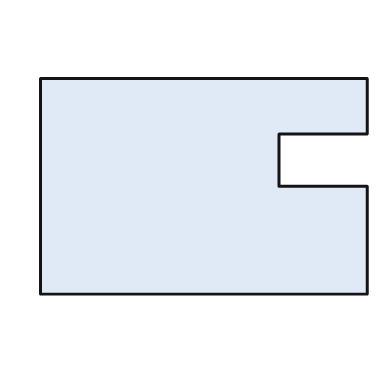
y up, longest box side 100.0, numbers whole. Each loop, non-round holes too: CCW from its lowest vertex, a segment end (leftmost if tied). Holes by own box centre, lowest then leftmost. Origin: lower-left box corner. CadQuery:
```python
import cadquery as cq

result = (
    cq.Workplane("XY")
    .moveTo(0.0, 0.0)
    .lineTo(100.0, 0.0)
    .lineTo(100.0, 33.0)
    .lineTo(73.0, 33.0)
    .lineTo(73.0, 49.0)
    .lineTo(100.0, 49.0)
    .lineTo(100.0, 66.0)
    .lineTo(0.0, 66.0)
    .close()
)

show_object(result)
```